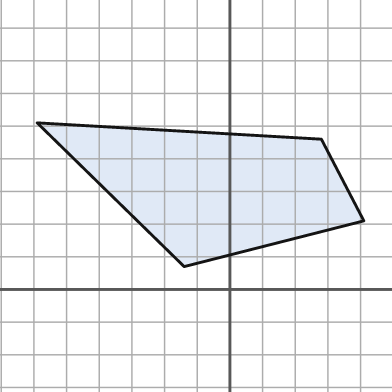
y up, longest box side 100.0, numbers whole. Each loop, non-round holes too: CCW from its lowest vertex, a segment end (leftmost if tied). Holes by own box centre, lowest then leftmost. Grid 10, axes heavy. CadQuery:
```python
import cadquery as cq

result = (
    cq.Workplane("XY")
    .moveTo(-14.0, 7.0)
    .lineTo(41.0, 21.0)
    .lineTo(28.0, 46.0)
    .lineTo(-59.0, 51.0)
    .close()
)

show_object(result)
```